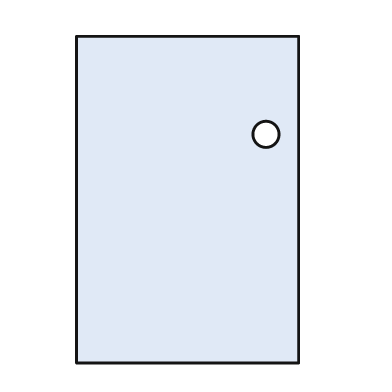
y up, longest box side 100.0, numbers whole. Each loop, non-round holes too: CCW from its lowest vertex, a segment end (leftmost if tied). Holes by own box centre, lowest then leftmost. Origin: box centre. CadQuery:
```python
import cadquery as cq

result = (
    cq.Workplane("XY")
    .moveTo(-34.0, -50.0)
    .lineTo(34.0, -50.0)
    .lineTo(34.0, 50.0)
    .lineTo(-34.0, 50.0)
    .close()
    .moveTo(24.0, 20.0)
    .circle(4.0)
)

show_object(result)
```